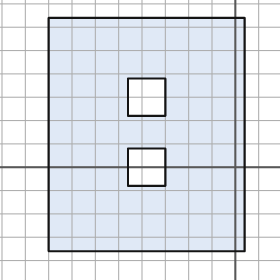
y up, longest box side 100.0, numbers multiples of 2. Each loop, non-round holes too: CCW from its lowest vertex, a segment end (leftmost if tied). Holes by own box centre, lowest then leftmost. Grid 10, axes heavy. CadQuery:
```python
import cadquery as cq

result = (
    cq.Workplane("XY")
    .moveTo(-80.0, -36.0)
    .lineTo(4.0, -36.0)
    .lineTo(4.0, 64.0)
    .lineTo(-80.0, 64.0)
    .close()
    .moveTo(-46.0, -8.0)
    .lineTo(-30.0, -8.0)
    .lineTo(-30.0, 8.0)
    .lineTo(-46.0, 8.0)
    .close()
    .moveTo(-46.0, 22.0)
    .lineTo(-30.0, 22.0)
    .lineTo(-30.0, 38.0)
    .lineTo(-46.0, 38.0)
    .close()
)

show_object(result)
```